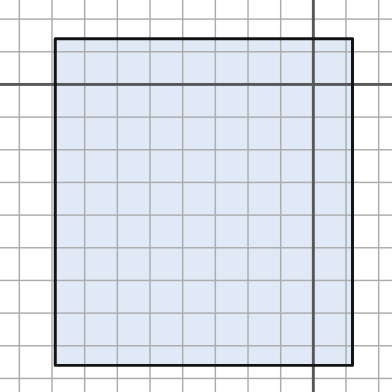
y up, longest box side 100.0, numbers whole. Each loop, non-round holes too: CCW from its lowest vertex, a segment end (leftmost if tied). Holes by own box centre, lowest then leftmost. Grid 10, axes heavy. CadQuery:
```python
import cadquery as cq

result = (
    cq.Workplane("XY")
    .moveTo(-79.0, -86.0)
    .lineTo(12.0, -86.0)
    .lineTo(12.0, 14.0)
    .lineTo(-79.0, 14.0)
    .close()
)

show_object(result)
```